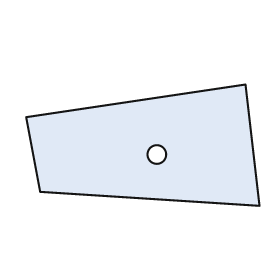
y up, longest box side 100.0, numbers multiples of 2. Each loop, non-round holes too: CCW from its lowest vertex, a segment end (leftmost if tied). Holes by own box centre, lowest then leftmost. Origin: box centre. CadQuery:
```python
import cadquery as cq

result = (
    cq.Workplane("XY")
    .moveTo(50.0, -26.0)
    .lineTo(44.0, 26.0)
    .lineTo(-50.0, 12.0)
    .lineTo(-44.0, -20.0)
    .close()
    .moveTo(6.0, -4.0)
    .circle(4.0)
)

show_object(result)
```